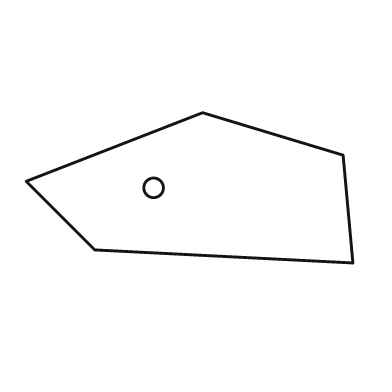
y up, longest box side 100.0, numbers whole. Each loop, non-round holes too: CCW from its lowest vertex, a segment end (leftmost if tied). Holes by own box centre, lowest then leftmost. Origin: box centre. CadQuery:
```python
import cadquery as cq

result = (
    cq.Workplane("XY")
    .moveTo(50.0, -23.0)
    .lineTo(47.0, 10.0)
    .lineTo(4.0, 23.0)
    .lineTo(-50.0, 2.0)
    .lineTo(-29.0, -19.0)
    .close()
    .moveTo(-11.0, 0.0)
    .circle(3.0)
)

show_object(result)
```